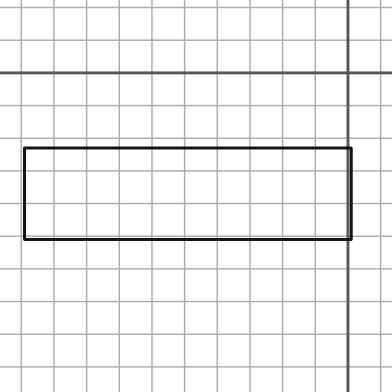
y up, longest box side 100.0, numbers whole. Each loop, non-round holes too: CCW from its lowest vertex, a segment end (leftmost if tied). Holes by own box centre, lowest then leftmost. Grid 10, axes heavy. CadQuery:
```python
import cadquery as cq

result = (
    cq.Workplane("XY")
    .moveTo(-99.0, -51.0)
    .lineTo(1.0, -51.0)
    .lineTo(1.0, -23.0)
    .lineTo(-99.0, -23.0)
    .close()
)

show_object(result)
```